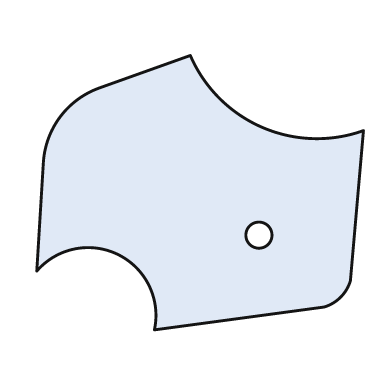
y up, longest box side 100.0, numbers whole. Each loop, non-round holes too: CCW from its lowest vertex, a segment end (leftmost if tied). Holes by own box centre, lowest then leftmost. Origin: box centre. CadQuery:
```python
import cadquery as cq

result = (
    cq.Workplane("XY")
    .moveTo(-14.0, -42.0)
    .lineTo(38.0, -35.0)
    .threePointArc((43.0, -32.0), (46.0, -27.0))
    .lineTo(50.0, 19.0)
    .threePointArc((19.0, 20.0), (-3.0, 42.0))
    .lineTo(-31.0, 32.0)
    .threePointArc((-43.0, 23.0), (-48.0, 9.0))
    .lineTo(-50.0, -24.0)
    .threePointArc((-25.0, -19.0), (-14.0, -42.0))
    .close()
    .moveTo(18.0, -13.0)
    .circle(4.0)
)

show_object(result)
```